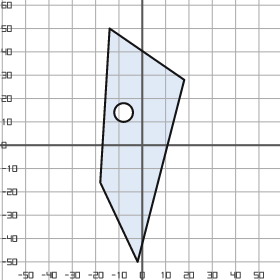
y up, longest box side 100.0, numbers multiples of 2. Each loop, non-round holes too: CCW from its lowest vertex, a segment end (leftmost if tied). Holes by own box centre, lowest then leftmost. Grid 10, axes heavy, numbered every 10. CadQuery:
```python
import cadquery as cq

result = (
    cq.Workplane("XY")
    .moveTo(-2.0, -50.0)
    .lineTo(18.0, 28.0)
    .lineTo(-14.0, 50.0)
    .lineTo(-18.0, -16.0)
    .close()
    .moveTo(-8.0, 14.0)
    .circle(4.0)
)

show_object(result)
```